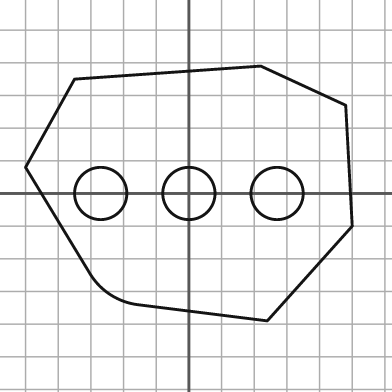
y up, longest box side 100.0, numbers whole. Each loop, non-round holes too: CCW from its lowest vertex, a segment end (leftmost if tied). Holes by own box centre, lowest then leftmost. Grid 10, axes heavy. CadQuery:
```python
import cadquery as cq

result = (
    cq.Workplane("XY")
    .moveTo(24.0, -39.0)
    .lineTo(50.0, -10.0)
    .lineTo(48.0, 27.0)
    .lineTo(22.0, 39.0)
    .lineTo(-35.0, 35.0)
    .lineTo(-50.0, 8.0)
    .lineTo(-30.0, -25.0)
    .threePointArc((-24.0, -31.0), (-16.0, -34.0))
    .close()
    .moveTo(-27.0, 0.0)
    .circle(8.0)
    .moveTo(0.0, 0.0)
    .circle(8.0)
    .moveTo(27.0, 0.0)
    .circle(8.0)
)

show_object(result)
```